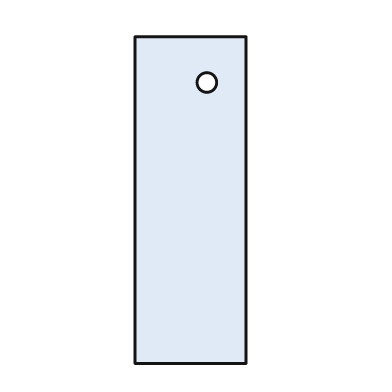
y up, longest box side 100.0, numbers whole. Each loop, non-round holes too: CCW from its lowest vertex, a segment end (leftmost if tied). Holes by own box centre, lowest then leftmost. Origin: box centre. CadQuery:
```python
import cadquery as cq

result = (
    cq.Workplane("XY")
    .moveTo(-17.0, -50.0)
    .lineTo(17.0, -50.0)
    .lineTo(17.0, 50.0)
    .lineTo(-17.0, 50.0)
    .close()
    .moveTo(5.0, 36.0)
    .circle(3.0)
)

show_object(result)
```